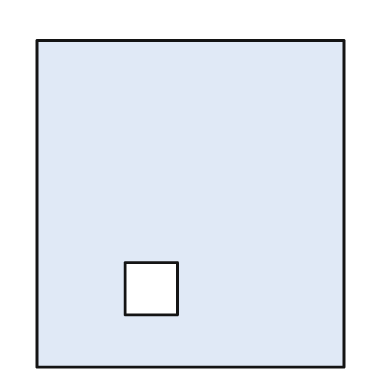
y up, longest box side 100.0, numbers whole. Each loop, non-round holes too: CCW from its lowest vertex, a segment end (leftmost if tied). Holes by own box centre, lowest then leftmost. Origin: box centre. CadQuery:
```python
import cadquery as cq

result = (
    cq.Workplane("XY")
    .moveTo(-47.0, -50.0)
    .lineTo(47.0, -50.0)
    .lineTo(47.0, 50.0)
    .lineTo(-47.0, 50.0)
    .close()
    .moveTo(-20.0, -34.0)
    .lineTo(-4.0, -34.0)
    .lineTo(-4.0, -18.0)
    .lineTo(-20.0, -18.0)
    .close()
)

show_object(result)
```